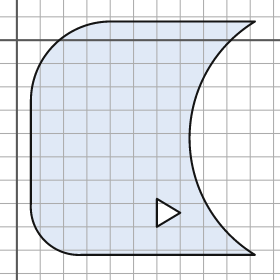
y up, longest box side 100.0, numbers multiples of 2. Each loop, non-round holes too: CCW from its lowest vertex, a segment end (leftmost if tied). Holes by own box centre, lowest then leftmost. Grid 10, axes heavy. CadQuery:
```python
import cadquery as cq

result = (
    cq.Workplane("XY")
    .moveTo(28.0, -92.0)
    .lineTo(102.0, -92.0)
    .threePointArc((74.0, -42.0), (102.0, 8.0))
    .lineTo(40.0, 8.0)
    .threePointArc((16.0, -2.0), (6.0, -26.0))
    .lineTo(6.0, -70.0)
    .threePointArc((12.0, -86.0), (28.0, -92.0))
    .close()
    .moveTo(60.0, -80.0)
    .lineTo(70.0, -74.0)
    .lineTo(60.0, -68.0)
    .close()
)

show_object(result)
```